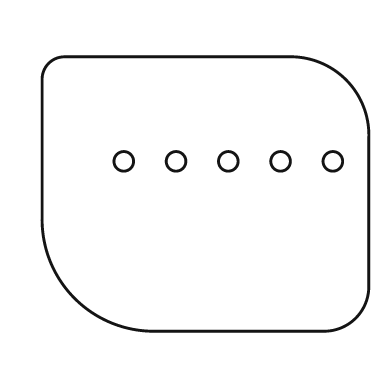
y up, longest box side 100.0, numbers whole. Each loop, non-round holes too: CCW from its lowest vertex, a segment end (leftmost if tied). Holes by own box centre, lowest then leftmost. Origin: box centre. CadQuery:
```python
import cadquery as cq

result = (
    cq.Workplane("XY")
    .moveTo(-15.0, -42.0)
    .lineTo(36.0, -42.0)
    .threePointArc((46.0, -38.0), (50.0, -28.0))
    .lineTo(50.0, 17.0)
    .threePointArc((43.0, 35.0), (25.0, 42.0))
    .lineTo(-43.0, 42.0)
    .threePointArc((-48.0, 40.0), (-50.0, 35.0))
    .lineTo(-50.0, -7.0)
    .threePointArc((-40.0, -32.0), (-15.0, -42.0))
    .close()
    .moveTo(-25.0, 10.0)
    .circle(3.0)
    .moveTo(-9.0, 10.0)
    .circle(3.0)
    .moveTo(7.0, 10.0)
    .circle(3.0)
    .moveTo(23.0, 10.0)
    .circle(3.0)
    .moveTo(39.0, 10.0)
    .circle(3.0)
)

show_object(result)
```